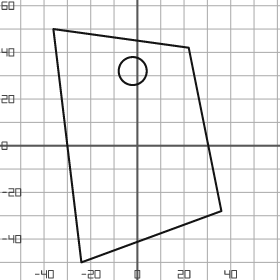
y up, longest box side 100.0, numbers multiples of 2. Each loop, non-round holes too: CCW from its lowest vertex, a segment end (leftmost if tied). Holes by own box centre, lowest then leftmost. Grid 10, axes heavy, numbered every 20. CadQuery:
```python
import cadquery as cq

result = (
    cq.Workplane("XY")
    .moveTo(-24.0, -50.0)
    .lineTo(36.0, -28.0)
    .lineTo(22.0, 42.0)
    .lineTo(-36.0, 50.0)
    .close()
    .moveTo(-2.0, 32.0)
    .circle(6.0)
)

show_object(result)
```